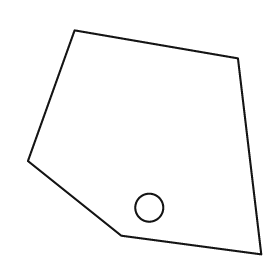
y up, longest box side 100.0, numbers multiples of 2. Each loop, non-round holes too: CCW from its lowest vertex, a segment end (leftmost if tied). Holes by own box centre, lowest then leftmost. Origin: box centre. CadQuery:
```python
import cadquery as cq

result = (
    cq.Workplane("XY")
    .moveTo(50.0, -48.0)
    .lineTo(40.0, 36.0)
    .lineTo(-30.0, 48.0)
    .lineTo(-50.0, -8.0)
    .lineTo(-10.0, -40.0)
    .close()
    .moveTo(2.0, -28.0)
    .circle(6.0)
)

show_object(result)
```